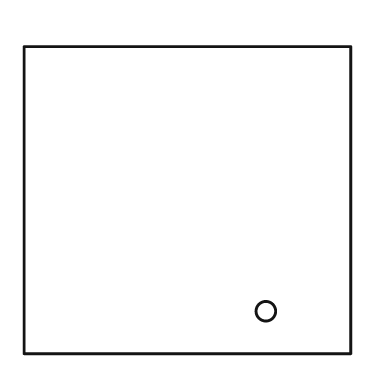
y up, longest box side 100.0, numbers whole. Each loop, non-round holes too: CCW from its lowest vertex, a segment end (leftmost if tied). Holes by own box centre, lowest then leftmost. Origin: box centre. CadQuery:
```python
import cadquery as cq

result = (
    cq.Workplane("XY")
    .moveTo(-50.0, -47.0)
    .lineTo(50.0, -47.0)
    .lineTo(50.0, 47.0)
    .lineTo(-50.0, 47.0)
    .close()
    .moveTo(24.0, -34.0)
    .circle(3.0)
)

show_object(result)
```